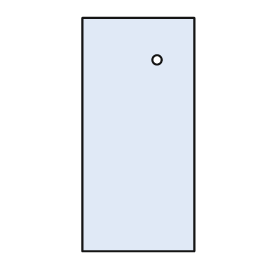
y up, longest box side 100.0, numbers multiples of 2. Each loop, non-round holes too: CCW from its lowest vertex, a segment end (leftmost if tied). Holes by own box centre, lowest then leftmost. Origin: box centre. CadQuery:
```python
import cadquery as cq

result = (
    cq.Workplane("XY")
    .moveTo(-24.0, -50.0)
    .lineTo(24.0, -50.0)
    .lineTo(24.0, 50.0)
    .lineTo(-24.0, 50.0)
    .close()
    .moveTo(8.0, 32.0)
    .circle(2.0)
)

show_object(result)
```